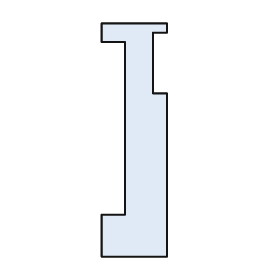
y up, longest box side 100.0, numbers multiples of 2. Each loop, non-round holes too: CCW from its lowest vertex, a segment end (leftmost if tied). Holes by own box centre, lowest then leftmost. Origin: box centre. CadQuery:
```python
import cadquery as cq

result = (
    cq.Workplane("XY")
    .moveTo(-14.0, -50.0)
    .lineTo(14.0, -50.0)
    .lineTo(14.0, 20.0)
    .lineTo(8.0, 20.0)
    .lineTo(8.0, 46.0)
    .lineTo(14.0, 46.0)
    .lineTo(14.0, 50.0)
    .lineTo(-14.0, 50.0)
    .lineTo(-14.0, 42.0)
    .lineTo(-4.0, 42.0)
    .lineTo(-4.0, -32.0)
    .lineTo(-14.0, -32.0)
    .close()
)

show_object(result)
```